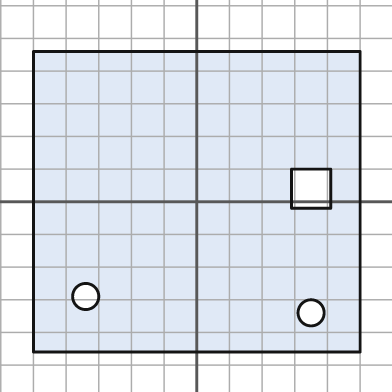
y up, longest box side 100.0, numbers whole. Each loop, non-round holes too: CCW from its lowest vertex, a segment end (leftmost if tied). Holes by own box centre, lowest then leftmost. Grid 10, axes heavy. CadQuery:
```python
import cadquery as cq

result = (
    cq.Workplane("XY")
    .moveTo(-50.0, -46.0)
    .lineTo(50.0, -46.0)
    .lineTo(50.0, 46.0)
    .lineTo(-50.0, 46.0)
    .close()
    .moveTo(35.0, -34.0)
    .circle(4.0)
    .moveTo(-34.0, -29.0)
    .circle(4.0)
    .moveTo(29.0, -2.0)
    .lineTo(41.0, -2.0)
    .lineTo(41.0, 10.0)
    .lineTo(29.0, 10.0)
    .close()
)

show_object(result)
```